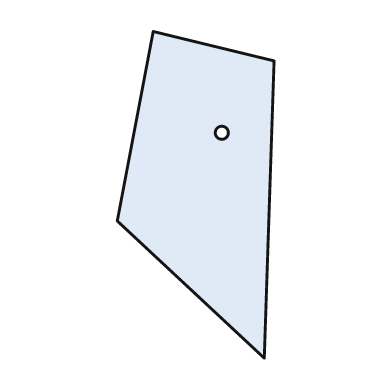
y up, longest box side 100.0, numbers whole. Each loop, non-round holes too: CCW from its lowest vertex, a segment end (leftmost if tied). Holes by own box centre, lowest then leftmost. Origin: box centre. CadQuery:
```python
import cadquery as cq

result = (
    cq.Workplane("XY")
    .moveTo(21.0, -50.0)
    .lineTo(24.0, 41.0)
    .lineTo(-13.0, 50.0)
    .lineTo(-24.0, -8.0)
    .close()
    .moveTo(8.0, 19.0)
    .circle(2.0)
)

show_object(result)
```